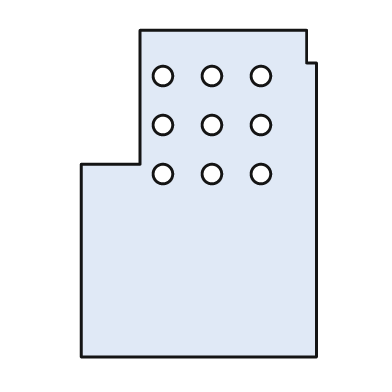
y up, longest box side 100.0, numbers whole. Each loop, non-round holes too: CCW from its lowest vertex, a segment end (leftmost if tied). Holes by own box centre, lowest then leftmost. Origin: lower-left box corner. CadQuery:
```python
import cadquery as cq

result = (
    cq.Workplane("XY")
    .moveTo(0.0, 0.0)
    .lineTo(72.0, 0.0)
    .lineTo(72.0, 90.0)
    .lineTo(69.0, 90.0)
    .lineTo(69.0, 100.0)
    .lineTo(18.0, 100.0)
    .lineTo(18.0, 59.0)
    .lineTo(0.0, 59.0)
    .close()
    .moveTo(25.0, 56.0)
    .circle(3.0)
    .moveTo(40.0, 56.0)
    .circle(3.0)
    .moveTo(55.0, 56.0)
    .circle(3.0)
    .moveTo(25.0, 71.0)
    .circle(3.0)
    .moveTo(40.0, 71.0)
    .circle(3.0)
    .moveTo(55.0, 71.0)
    .circle(3.0)
    .moveTo(25.0, 86.0)
    .circle(3.0)
    .moveTo(40.0, 86.0)
    .circle(3.0)
    .moveTo(55.0, 86.0)
    .circle(3.0)
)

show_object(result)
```